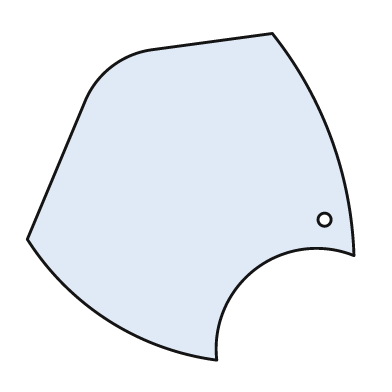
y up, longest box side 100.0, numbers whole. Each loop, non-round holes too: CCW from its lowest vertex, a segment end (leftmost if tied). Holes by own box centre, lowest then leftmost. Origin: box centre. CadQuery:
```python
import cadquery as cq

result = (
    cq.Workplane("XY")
    .moveTo(8.0, -50.0)
    .threePointArc((20.0, -22.0), (50.0, -18.0))
    .threePointArc((43.0, 18.0), (25.0, 50.0))
    .lineTo(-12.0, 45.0)
    .threePointArc((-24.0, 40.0), (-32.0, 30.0))
    .lineTo(-50.0, -13.0)
    .threePointArc((-25.0, -38.0), (8.0, -50.0))
    .close()
    .moveTo(41.0, -7.0)
    .circle(2.0)
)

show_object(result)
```